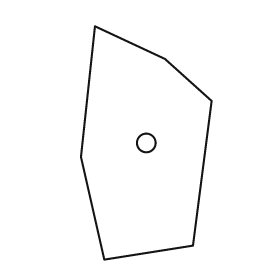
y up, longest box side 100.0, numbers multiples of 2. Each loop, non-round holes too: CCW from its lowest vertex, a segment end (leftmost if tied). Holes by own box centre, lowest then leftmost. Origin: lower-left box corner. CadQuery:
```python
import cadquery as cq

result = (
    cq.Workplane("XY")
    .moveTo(10.0, 0.0)
    .lineTo(48.0, 6.0)
    .lineTo(56.0, 68.0)
    .lineTo(36.0, 86.0)
    .lineTo(6.0, 100.0)
    .lineTo(0.0, 44.0)
    .close()
    .moveTo(28.0, 50.0)
    .circle(4.0)
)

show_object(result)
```